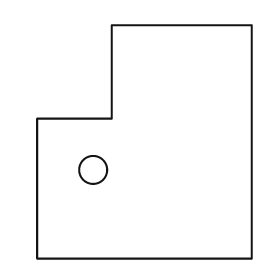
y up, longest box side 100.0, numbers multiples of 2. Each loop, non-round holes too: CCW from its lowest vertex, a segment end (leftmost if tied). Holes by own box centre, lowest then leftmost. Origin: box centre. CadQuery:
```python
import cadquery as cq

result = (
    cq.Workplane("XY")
    .moveTo(-46.0, -50.0)
    .lineTo(46.0, -50.0)
    .lineTo(46.0, 50.0)
    .lineTo(-14.0, 50.0)
    .lineTo(-14.0, 10.0)
    .lineTo(-46.0, 10.0)
    .close()
    .moveTo(-22.0, -12.0)
    .circle(6.0)
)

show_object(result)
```